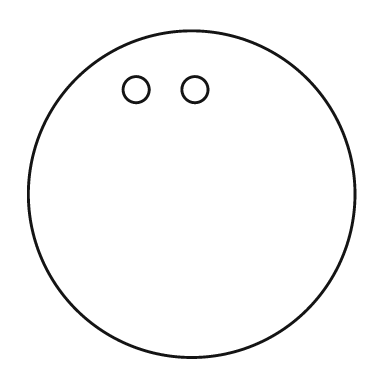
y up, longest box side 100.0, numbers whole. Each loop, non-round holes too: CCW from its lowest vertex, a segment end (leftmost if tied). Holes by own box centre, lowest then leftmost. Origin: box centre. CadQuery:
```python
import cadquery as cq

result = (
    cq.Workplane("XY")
    .moveTo(0.0, 0.0)
    .circle(50.0)
    .moveTo(-17.0, 32.0)
    .circle(4.0)
    .moveTo(1.0, 32.0)
    .circle(4.0)
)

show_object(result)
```